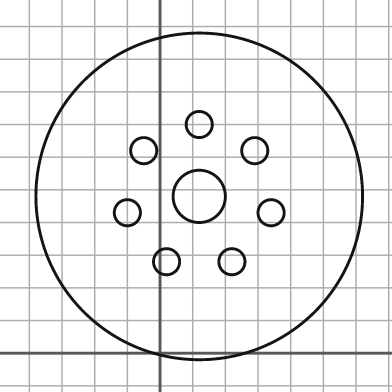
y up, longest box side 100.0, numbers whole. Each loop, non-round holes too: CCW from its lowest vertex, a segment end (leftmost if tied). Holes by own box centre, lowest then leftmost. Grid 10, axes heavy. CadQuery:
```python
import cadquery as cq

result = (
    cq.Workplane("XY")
    .moveTo(12.0, 48.0)
    .circle(50.0)
    .moveTo(2.0, 28.0)
    .circle(4.0)
    .moveTo(22.0, 28.0)
    .circle(4.0)
    .moveTo(-10.0, 43.0)
    .circle(4.0)
    .moveTo(34.0, 43.0)
    .circle(4.0)
    .moveTo(12.0, 48.0)
    .circle(8.0)
    .moveTo(-5.0, 62.0)
    .circle(4.0)
    .moveTo(29.0, 62.0)
    .circle(4.0)
    .moveTo(12.0, 70.0)
    .circle(4.0)
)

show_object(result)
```